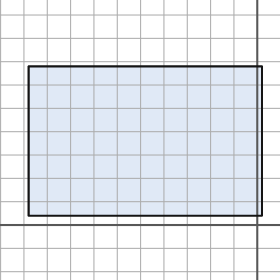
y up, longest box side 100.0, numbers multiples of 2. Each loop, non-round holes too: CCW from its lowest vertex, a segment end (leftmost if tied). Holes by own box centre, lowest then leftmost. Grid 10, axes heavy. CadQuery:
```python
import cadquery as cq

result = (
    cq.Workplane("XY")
    .moveTo(-98.0, 4.0)
    .lineTo(2.0, 4.0)
    .lineTo(2.0, 68.0)
    .lineTo(-98.0, 68.0)
    .close()
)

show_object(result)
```